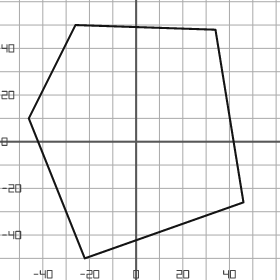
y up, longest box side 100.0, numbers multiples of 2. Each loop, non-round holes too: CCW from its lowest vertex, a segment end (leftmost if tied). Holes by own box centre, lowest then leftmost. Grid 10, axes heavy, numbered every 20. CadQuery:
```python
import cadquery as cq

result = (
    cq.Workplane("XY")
    .moveTo(-22.0, -50.0)
    .lineTo(46.0, -26.0)
    .lineTo(34.0, 48.0)
    .lineTo(-26.0, 50.0)
    .lineTo(-46.0, 10.0)
    .close()
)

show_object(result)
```